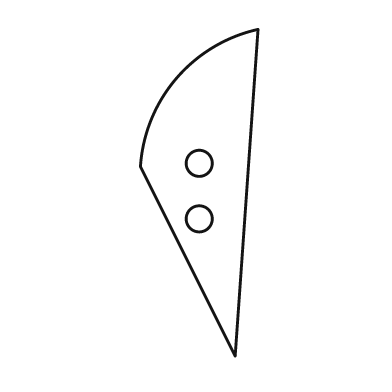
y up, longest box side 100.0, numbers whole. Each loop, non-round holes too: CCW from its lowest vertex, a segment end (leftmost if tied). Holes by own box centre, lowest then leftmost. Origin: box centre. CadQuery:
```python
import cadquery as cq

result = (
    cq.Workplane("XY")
    .moveTo(11.0, -50.0)
    .lineTo(18.0, 50.0)
    .threePointArc((-7.0, 35.0), (-18.0, 8.0))
    .close()
    .moveTo(0.0, -8.0)
    .circle(4.0)
    .moveTo(0.0, 9.0)
    .circle(4.0)
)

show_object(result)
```